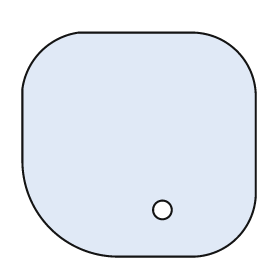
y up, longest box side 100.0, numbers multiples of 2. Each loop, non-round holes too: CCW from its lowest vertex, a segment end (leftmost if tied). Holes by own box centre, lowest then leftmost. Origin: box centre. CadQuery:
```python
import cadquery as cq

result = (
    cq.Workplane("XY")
    .moveTo(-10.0, -48.0)
    .lineTo(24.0, -48.0)
    .threePointArc((42.0, -40.0), (50.0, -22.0))
    .lineTo(50.0, 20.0)
    .threePointArc((42.0, 40.0), (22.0, 48.0))
    .lineTo(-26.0, 48.0)
    .threePointArc((-42.0, 40.0), (-50.0, 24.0))
    .lineTo(-50.0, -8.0)
    .threePointArc((-38.0, -36.0), (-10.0, -48.0))
    .close()
    .moveTo(10.0, -28.0)
    .circle(4.0)
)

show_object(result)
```